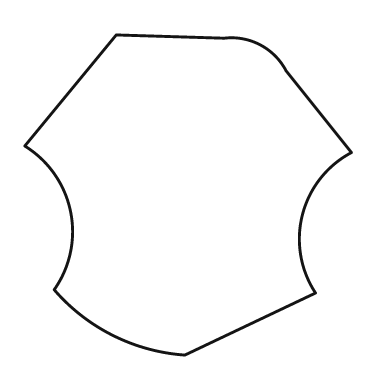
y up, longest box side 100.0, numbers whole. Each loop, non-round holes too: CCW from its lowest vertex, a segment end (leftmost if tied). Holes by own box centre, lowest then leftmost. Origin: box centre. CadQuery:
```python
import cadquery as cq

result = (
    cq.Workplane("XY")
    .moveTo(-1.0, -49.0)
    .lineTo(39.0, -30.0)
    .threePointArc((35.0, -6.0), (50.0, 13.0))
    .lineTo(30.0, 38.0)
    .threePointArc((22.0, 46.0), (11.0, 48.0))
    .lineTo(-22.0, 49.0)
    .lineTo(-50.0, 15.0)
    .threePointArc((-36.0, -5.0), (-41.0, -29.0))
    .threePointArc((-23.0, -43.0), (-1.0, -49.0))
    .close()
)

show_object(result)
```